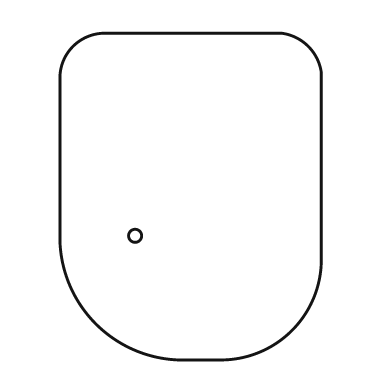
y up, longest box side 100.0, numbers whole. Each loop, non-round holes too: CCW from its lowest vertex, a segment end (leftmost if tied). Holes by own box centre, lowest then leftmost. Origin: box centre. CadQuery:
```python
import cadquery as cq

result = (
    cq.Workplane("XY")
    .moveTo(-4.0, -50.0)
    .lineTo(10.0, -50.0)
    .threePointArc((31.0, -41.0), (40.0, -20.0))
    .lineTo(40.0, 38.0)
    .threePointArc((36.0, 46.0), (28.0, 50.0))
    .lineTo(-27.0, 50.0)
    .threePointArc((-36.0, 46.0), (-40.0, 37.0))
    .lineTo(-40.0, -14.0)
    .threePointArc((-29.0, -39.0), (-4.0, -50.0))
    .close()
    .moveTo(-17.0, -12.0)
    .circle(2.0)
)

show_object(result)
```